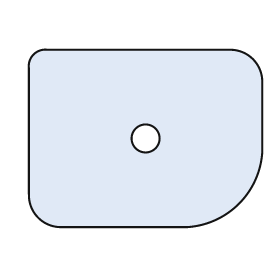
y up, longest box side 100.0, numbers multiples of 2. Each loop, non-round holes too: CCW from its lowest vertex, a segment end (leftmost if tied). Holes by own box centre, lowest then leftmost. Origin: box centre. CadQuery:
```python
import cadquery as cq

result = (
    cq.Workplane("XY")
    .moveTo(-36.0, -38.0)
    .lineTo(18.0, -38.0)
    .threePointArc((40.0, -28.0), (50.0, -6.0))
    .lineTo(50.0, 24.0)
    .threePointArc((46.0, 34.0), (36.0, 38.0))
    .lineTo(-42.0, 38.0)
    .threePointArc((-48.0, 36.0), (-50.0, 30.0))
    .lineTo(-50.0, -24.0)
    .threePointArc((-46.0, -34.0), (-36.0, -38.0))
    .close()
    .moveTo(0.0, 0.0)
    .circle(6.0)
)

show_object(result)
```